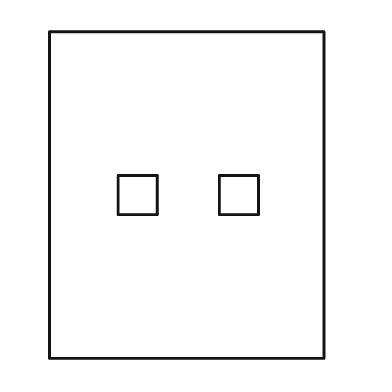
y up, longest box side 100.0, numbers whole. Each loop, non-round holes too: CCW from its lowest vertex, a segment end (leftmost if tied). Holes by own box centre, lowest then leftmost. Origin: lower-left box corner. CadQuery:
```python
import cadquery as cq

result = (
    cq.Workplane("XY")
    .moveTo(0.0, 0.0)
    .lineTo(84.0, 0.0)
    .lineTo(84.0, 100.0)
    .lineTo(0.0, 100.0)
    .close()
    .moveTo(21.0, 44.0)
    .lineTo(33.0, 44.0)
    .lineTo(33.0, 56.0)
    .lineTo(21.0, 56.0)
    .close()
    .moveTo(52.0, 44.0)
    .lineTo(64.0, 44.0)
    .lineTo(64.0, 56.0)
    .lineTo(52.0, 56.0)
    .close()
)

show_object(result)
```